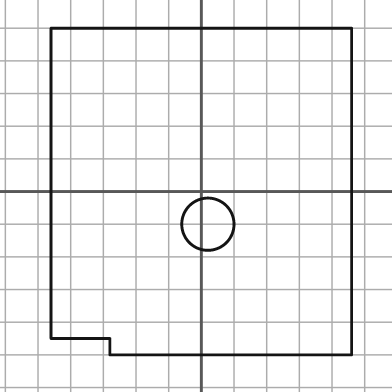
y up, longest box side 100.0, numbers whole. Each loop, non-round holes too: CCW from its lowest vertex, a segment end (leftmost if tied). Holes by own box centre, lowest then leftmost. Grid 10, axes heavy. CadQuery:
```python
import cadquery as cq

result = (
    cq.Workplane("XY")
    .moveTo(-28.0, -50.0)
    .lineTo(46.0, -50.0)
    .lineTo(46.0, 50.0)
    .lineTo(-46.0, 50.0)
    .lineTo(-46.0, -45.0)
    .lineTo(-28.0, -45.0)
    .close()
    .moveTo(2.0, -10.0)
    .circle(8.0)
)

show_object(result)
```